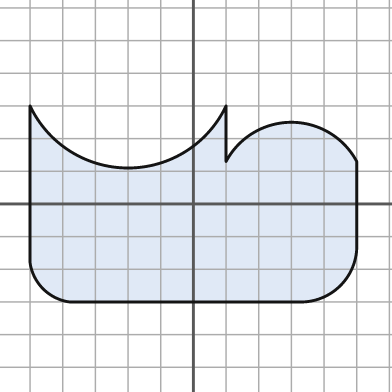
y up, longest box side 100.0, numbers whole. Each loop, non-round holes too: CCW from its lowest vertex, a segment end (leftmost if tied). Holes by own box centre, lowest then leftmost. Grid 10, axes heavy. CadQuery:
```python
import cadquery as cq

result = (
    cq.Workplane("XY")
    .moveTo(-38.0, -30.0)
    .lineTo(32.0, -30.0)
    .threePointArc((45.0, -25.0), (50.0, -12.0))
    .lineTo(50.0, 13.0)
    .threePointArc((30.0, 25.0), (10.0, 13.0))
    .lineTo(10.0, 30.0)
    .threePointArc((-20.0, 11.0), (-50.0, 30.0))
    .lineTo(-50.0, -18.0)
    .threePointArc((-46.0, -26.0), (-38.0, -30.0))
    .close()
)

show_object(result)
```